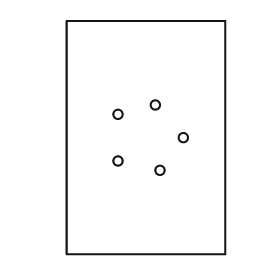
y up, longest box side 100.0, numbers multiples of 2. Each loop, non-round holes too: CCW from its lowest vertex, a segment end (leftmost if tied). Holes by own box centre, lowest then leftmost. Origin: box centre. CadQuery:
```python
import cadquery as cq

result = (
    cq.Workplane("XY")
    .moveTo(-34.0, -50.0)
    .lineTo(34.0, -50.0)
    .lineTo(34.0, 50.0)
    .lineTo(-34.0, 50.0)
    .close()
    .moveTo(6.0, -14.0)
    .circle(2.0)
    .moveTo(-12.0, -10.0)
    .circle(2.0)
    .moveTo(16.0, 0.0)
    .circle(2.0)
    .moveTo(-12.0, 10.0)
    .circle(2.0)
    .moveTo(4.0, 14.0)
    .circle(2.0)
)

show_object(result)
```